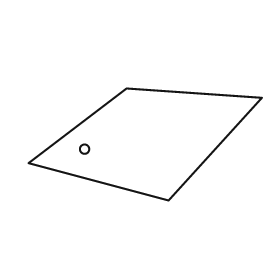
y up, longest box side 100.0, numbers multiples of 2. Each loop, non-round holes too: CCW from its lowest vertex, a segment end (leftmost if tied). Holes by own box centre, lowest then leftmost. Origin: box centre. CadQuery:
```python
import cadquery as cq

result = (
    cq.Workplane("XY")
    .moveTo(10.0, -24.0)
    .lineTo(50.0, 20.0)
    .lineTo(-8.0, 24.0)
    .lineTo(-50.0, -8.0)
    .close()
    .moveTo(-26.0, -2.0)
    .circle(2.0)
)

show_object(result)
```